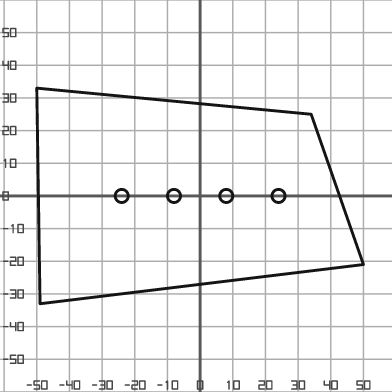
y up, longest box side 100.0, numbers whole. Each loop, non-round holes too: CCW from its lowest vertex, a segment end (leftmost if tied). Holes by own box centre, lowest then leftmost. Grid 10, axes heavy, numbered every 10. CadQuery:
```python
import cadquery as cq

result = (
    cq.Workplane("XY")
    .moveTo(-49.0, -33.0)
    .lineTo(50.0, -21.0)
    .lineTo(34.0, 25.0)
    .lineTo(-50.0, 33.0)
    .close()
    .moveTo(-24.0, 0.0)
    .circle(2.0)
    .moveTo(-8.0, 0.0)
    .circle(2.0)
    .moveTo(8.0, 0.0)
    .circle(2.0)
    .moveTo(24.0, 0.0)
    .circle(2.0)
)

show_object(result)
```